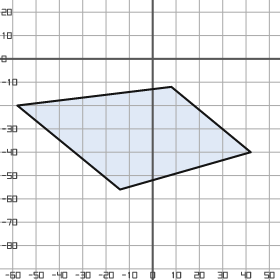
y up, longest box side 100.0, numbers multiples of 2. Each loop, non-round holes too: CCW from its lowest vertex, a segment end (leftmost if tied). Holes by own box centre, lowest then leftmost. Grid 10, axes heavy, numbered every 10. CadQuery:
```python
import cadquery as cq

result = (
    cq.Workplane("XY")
    .moveTo(-14.0, -56.0)
    .lineTo(42.0, -40.0)
    .lineTo(8.0, -12.0)
    .lineTo(-58.0, -20.0)
    .close()
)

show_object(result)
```